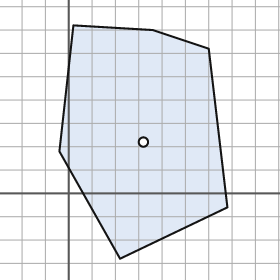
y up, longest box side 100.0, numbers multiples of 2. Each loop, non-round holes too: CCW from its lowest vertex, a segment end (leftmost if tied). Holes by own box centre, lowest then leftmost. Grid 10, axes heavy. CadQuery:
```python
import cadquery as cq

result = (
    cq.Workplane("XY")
    .moveTo(22.0, -28.0)
    .lineTo(68.0, -6.0)
    .lineTo(60.0, 62.0)
    .lineTo(36.0, 70.0)
    .lineTo(2.0, 72.0)
    .lineTo(-4.0, 18.0)
    .close()
    .moveTo(32.0, 22.0)
    .circle(2.0)
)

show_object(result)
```